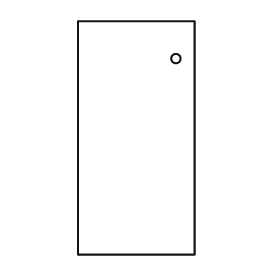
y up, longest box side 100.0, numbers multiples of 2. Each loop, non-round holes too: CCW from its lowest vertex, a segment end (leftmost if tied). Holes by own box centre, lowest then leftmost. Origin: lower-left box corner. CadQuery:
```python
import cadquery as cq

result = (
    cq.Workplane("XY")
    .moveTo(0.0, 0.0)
    .lineTo(50.0, 0.0)
    .lineTo(50.0, 100.0)
    .lineTo(0.0, 100.0)
    .close()
    .moveTo(42.0, 84.0)
    .circle(2.0)
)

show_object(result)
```